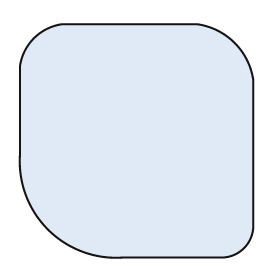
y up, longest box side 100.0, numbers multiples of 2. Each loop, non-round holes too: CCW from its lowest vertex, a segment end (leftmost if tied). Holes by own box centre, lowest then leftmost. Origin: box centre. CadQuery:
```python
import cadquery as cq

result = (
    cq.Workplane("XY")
    .moveTo(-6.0, -50.0)
    .lineTo(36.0, -50.0)
    .threePointArc((46.0, -46.0), (50.0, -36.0))
    .lineTo(50.0, 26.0)
    .threePointArc((42.0, 42.0), (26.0, 50.0))
    .lineTo(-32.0, 50.0)
    .threePointArc((-44.0, 44.0), (-50.0, 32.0))
    .lineTo(-50.0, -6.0)
    .threePointArc((-38.0, -38.0), (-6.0, -50.0))
    .close()
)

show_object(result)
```